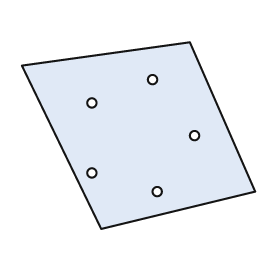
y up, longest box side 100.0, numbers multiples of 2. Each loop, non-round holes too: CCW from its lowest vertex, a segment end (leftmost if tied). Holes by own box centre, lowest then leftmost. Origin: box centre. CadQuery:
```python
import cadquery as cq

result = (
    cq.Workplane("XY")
    .moveTo(-16.0, -40.0)
    .lineTo(50.0, -24.0)
    .lineTo(22.0, 40.0)
    .lineTo(-50.0, 30.0)
    .close()
    .moveTo(8.0, -24.0)
    .circle(2.0)
    .moveTo(-20.0, -16.0)
    .circle(2.0)
    .moveTo(24.0, 0.0)
    .circle(2.0)
    .moveTo(-20.0, 14.0)
    .circle(2.0)
    .moveTo(6.0, 24.0)
    .circle(2.0)
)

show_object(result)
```